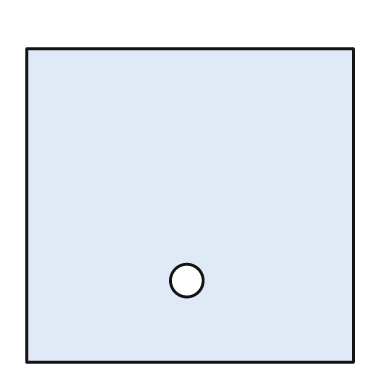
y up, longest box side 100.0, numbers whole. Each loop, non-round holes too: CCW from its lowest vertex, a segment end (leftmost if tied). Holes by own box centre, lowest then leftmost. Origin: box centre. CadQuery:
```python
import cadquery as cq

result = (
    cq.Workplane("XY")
    .moveTo(-50.0, -48.0)
    .lineTo(50.0, -48.0)
    .lineTo(50.0, 48.0)
    .lineTo(-50.0, 48.0)
    .close()
    .moveTo(-1.0, -23.0)
    .circle(5.0)
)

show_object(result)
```